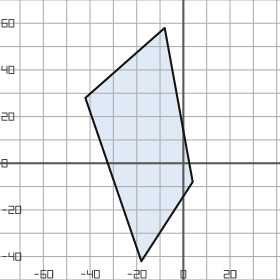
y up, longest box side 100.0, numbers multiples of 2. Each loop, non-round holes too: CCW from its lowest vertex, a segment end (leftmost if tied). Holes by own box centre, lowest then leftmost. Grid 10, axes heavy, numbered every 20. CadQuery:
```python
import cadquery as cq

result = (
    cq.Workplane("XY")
    .moveTo(-18.0, -42.0)
    .lineTo(4.0, -8.0)
    .lineTo(-8.0, 58.0)
    .lineTo(-42.0, 28.0)
    .close()
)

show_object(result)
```